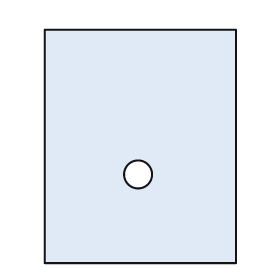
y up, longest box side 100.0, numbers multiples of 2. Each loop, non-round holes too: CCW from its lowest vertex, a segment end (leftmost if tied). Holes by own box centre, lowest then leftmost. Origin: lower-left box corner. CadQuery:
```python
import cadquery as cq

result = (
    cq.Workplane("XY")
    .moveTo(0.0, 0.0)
    .lineTo(82.0, 0.0)
    .lineTo(82.0, 100.0)
    .lineTo(0.0, 100.0)
    .close()
    .moveTo(40.0, 38.0)
    .circle(6.0)
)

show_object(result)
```